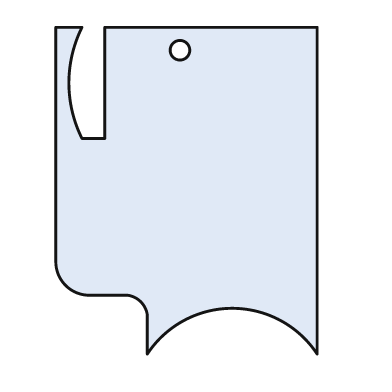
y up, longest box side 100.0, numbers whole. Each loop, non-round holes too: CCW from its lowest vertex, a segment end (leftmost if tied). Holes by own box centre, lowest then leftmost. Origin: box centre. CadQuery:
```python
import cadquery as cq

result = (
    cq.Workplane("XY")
    .moveTo(-12.0, -50.0)
    .threePointArc((14.0, -36.0), (40.0, -50.0))
    .lineTo(40.0, 50.0)
    .lineTo(-25.0, 50.0)
    .lineTo(-25.0, 16.0)
    .lineTo(-32.0, 16.0)
    .threePointArc((-36.0, 33.0), (-32.0, 50.0))
    .lineTo(-40.0, 50.0)
    .lineTo(-40.0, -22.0)
    .threePointArc((-37.0, -29.0), (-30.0, -32.0))
    .lineTo(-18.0, -32.0)
    .threePointArc((-14.0, -34.0), (-12.0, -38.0))
    .close()
    .moveTo(-2.0, 43.0)
    .circle(3.0)
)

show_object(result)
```